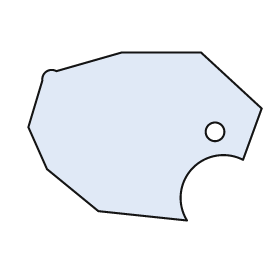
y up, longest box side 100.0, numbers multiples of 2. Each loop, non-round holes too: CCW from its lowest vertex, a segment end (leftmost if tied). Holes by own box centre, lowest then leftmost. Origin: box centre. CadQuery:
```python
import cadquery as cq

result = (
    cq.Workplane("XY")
    .moveTo(18.0, -36.0)
    .threePointArc((20.0, -14.0), (42.0, -10.0))
    .lineTo(50.0, 12.0)
    .lineTo(24.0, 36.0)
    .lineTo(-10.0, 36.0)
    .lineTo(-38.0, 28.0)
    .threePointArc((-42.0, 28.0), (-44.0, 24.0))
    .lineTo(-50.0, 4.0)
    .lineTo(-42.0, -14.0)
    .lineTo(-20.0, -32.0)
    .close()
    .moveTo(30.0, 2.0)
    .circle(4.0)
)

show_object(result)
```